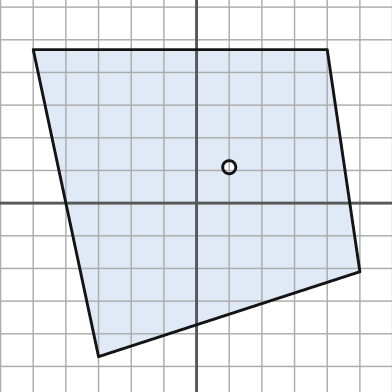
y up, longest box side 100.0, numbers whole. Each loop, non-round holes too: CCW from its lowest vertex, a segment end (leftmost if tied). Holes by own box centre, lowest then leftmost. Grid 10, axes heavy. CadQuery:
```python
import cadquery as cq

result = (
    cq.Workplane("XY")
    .moveTo(-30.0, -47.0)
    .lineTo(50.0, -21.0)
    .lineTo(40.0, 47.0)
    .lineTo(-50.0, 47.0)
    .close()
    .moveTo(10.0, 11.0)
    .circle(2.0)
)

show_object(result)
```